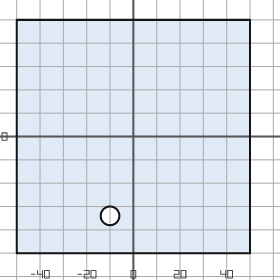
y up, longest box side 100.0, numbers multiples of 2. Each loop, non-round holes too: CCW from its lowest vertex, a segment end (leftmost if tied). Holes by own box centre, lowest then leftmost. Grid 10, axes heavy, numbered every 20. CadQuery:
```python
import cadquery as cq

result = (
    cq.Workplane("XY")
    .moveTo(-50.0, -50.0)
    .lineTo(50.0, -50.0)
    .lineTo(50.0, 50.0)
    .lineTo(-50.0, 50.0)
    .close()
    .moveTo(-10.0, -34.0)
    .circle(4.0)
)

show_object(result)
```